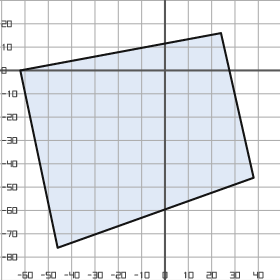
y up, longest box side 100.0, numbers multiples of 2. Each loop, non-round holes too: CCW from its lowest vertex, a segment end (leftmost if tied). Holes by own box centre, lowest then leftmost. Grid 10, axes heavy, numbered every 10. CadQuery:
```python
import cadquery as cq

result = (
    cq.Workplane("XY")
    .moveTo(-46.0, -76.0)
    .lineTo(38.0, -46.0)
    .lineTo(24.0, 16.0)
    .lineTo(-62.0, 0.0)
    .close()
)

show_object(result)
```